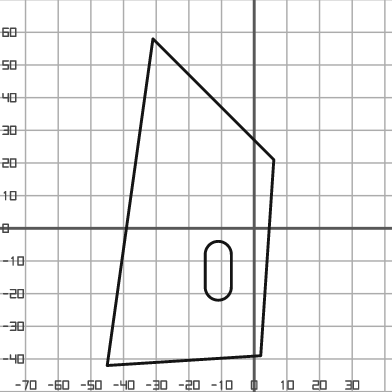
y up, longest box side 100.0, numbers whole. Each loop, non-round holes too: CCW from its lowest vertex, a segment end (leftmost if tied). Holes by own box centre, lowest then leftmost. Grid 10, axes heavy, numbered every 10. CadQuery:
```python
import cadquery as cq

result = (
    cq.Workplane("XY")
    .moveTo(-45.0, -42.0)
    .lineTo(2.0, -39.0)
    .lineTo(6.0, 21.0)
    .lineTo(-31.0, 58.0)
    .close()
    .moveTo(-15.0, -18.0)
    .threePointArc((-11.0, -22.0), (-7.0, -18.0))
    .lineTo(-7.0, -8.0)
    .threePointArc((-11.0, -4.0), (-15.0, -8.0))
    .close()
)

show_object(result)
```